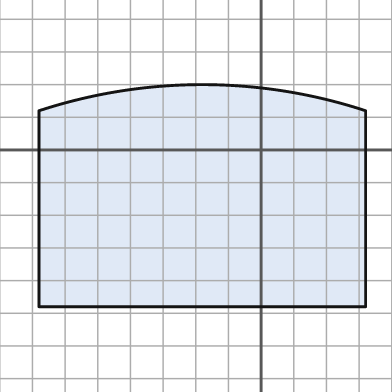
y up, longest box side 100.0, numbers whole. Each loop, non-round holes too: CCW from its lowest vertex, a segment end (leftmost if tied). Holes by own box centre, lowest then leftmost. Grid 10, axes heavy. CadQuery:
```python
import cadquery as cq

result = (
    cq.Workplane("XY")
    .moveTo(-68.0, -48.0)
    .lineTo(32.0, -48.0)
    .lineTo(32.0, 12.0)
    .threePointArc((-18.0, 20.0), (-68.0, 12.0))
    .close()
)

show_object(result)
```